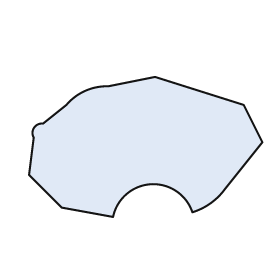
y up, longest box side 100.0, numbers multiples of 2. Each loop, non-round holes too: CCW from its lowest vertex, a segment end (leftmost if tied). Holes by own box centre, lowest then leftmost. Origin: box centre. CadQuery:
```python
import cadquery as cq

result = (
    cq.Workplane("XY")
    .moveTo(-14.0, -30.0)
    .threePointArc((2.0, -16.0), (20.0, -28.0))
    .threePointArc((28.0, -24.0), (34.0, -18.0))
    .lineTo(50.0, 2.0)
    .lineTo(42.0, 18.0)
    .lineTo(4.0, 30.0)
    .lineTo(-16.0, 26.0)
    .threePointArc((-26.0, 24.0), (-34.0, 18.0))
    .lineTo(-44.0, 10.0)
    .threePointArc((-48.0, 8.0), (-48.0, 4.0))
    .lineTo(-50.0, -12.0)
    .lineTo(-36.0, -26.0)
    .close()
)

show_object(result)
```